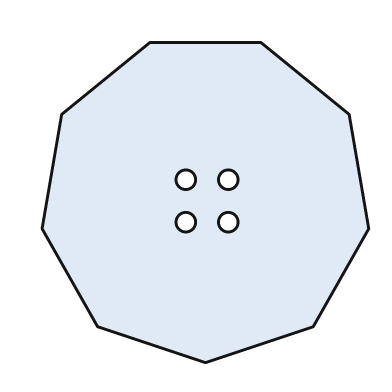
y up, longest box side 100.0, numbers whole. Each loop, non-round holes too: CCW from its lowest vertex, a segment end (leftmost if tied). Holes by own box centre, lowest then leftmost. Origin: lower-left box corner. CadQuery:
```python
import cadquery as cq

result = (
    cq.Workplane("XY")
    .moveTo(50.0, 0.0)
    .lineTo(83.0, 11.0)
    .lineTo(100.0, 41.0)
    .lineTo(94.0, 76.0)
    .lineTo(67.0, 98.0)
    .lineTo(33.0, 98.0)
    .lineTo(6.0, 76.0)
    .lineTo(0.0, 41.0)
    .lineTo(17.0, 11.0)
    .close()
    .moveTo(44.0, 43.0)
    .circle(3.0)
    .moveTo(57.0, 43.0)
    .circle(3.0)
    .moveTo(44.0, 56.0)
    .circle(3.0)
    .moveTo(57.0, 56.0)
    .circle(3.0)
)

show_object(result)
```